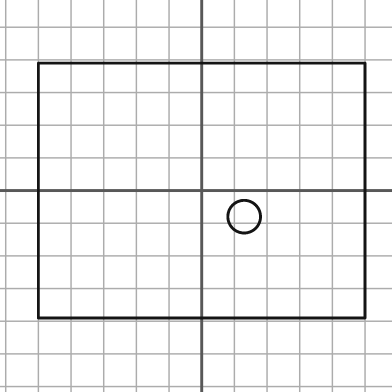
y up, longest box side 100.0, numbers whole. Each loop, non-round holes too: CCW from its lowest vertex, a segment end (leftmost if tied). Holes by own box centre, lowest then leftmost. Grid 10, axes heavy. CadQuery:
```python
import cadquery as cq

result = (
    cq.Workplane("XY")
    .moveTo(-50.0, -39.0)
    .lineTo(50.0, -39.0)
    .lineTo(50.0, 39.0)
    .lineTo(-50.0, 39.0)
    .close()
    .moveTo(13.0, -8.0)
    .circle(5.0)
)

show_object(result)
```